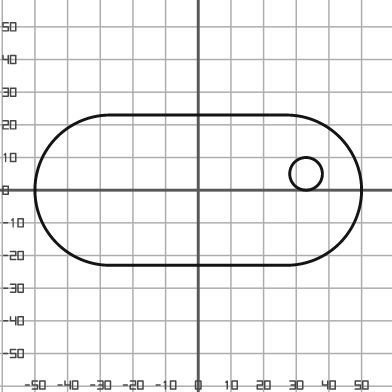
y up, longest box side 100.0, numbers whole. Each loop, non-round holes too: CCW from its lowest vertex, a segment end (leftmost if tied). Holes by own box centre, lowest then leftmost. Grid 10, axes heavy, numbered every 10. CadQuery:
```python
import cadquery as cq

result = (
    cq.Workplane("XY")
    .moveTo(-27.0, -23.0)
    .lineTo(27.0, -23.0)
    .threePointArc((50.0, 0.0), (27.0, 23.0))
    .lineTo(-27.0, 23.0)
    .threePointArc((-50.0, 0.0), (-27.0, -23.0))
    .close()
    .moveTo(33.0, 5.0)
    .circle(5.0)
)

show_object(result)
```